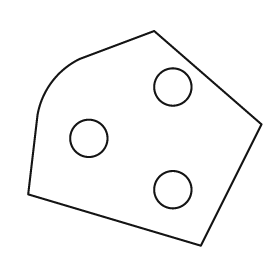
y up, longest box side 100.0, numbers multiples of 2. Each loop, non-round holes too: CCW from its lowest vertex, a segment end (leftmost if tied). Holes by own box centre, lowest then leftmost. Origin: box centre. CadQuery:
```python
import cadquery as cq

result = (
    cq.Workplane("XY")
    .moveTo(24.0, -46.0)
    .lineTo(50.0, 6.0)
    .lineTo(4.0, 46.0)
    .lineTo(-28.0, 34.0)
    .threePointArc((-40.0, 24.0), (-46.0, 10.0))
    .lineTo(-50.0, -24.0)
    .close()
    .moveTo(12.0, -22.0)
    .circle(8.0)
    .moveTo(-24.0, 0.0)
    .circle(8.0)
    .moveTo(12.0, 22.0)
    .circle(8.0)
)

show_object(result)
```